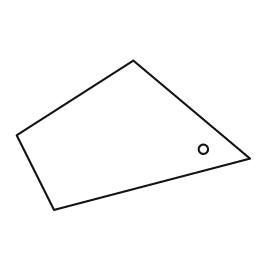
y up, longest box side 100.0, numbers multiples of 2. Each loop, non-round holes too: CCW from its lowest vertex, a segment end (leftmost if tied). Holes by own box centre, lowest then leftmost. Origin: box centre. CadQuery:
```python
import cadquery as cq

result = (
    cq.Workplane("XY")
    .moveTo(-34.0, -32.0)
    .lineTo(50.0, -10.0)
    .lineTo(0.0, 32.0)
    .lineTo(-50.0, 0.0)
    .close()
    .moveTo(30.0, -6.0)
    .circle(2.0)
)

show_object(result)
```